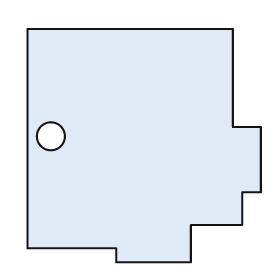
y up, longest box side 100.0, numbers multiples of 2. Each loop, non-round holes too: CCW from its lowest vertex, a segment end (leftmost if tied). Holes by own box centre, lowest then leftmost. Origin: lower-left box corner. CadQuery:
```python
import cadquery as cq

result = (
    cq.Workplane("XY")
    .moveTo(38.0, 0.0)
    .lineTo(70.0, 0.0)
    .lineTo(70.0, 16.0)
    .lineTo(92.0, 16.0)
    .lineTo(92.0, 30.0)
    .lineTo(100.0, 30.0)
    .lineTo(100.0, 58.0)
    .lineTo(88.0, 58.0)
    .lineTo(88.0, 100.0)
    .lineTo(0.0, 100.0)
    .lineTo(0.0, 6.0)
    .lineTo(38.0, 6.0)
    .close()
    .moveTo(10.0, 54.0)
    .circle(6.0)
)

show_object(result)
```